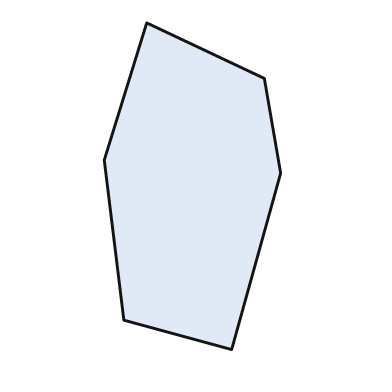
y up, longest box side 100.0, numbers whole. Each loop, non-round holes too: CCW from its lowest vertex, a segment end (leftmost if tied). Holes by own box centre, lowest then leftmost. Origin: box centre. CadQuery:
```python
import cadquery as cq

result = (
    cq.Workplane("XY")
    .moveTo(12.0, -50.0)
    .lineTo(27.0, 4.0)
    .lineTo(22.0, 33.0)
    .lineTo(-14.0, 50.0)
    .lineTo(-27.0, 8.0)
    .lineTo(-21.0, -41.0)
    .close()
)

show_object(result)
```